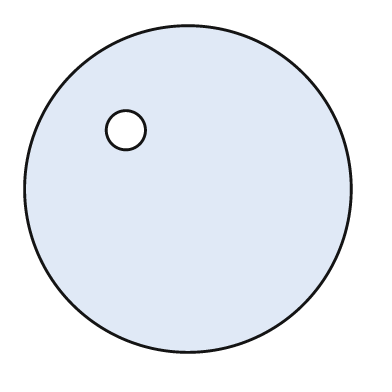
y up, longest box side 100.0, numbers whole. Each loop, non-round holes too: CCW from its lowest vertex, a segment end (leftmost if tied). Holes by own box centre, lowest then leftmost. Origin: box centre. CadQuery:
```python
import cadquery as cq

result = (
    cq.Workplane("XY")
    .moveTo(0.0, 0.0)
    .circle(50.0)
    .moveTo(-19.0, 18.0)
    .circle(6.0)
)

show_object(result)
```